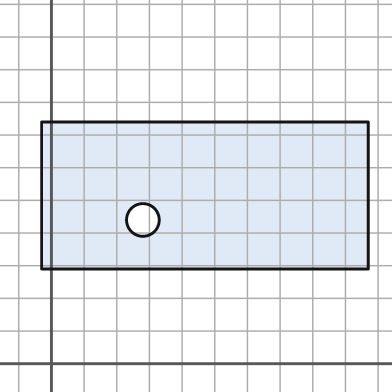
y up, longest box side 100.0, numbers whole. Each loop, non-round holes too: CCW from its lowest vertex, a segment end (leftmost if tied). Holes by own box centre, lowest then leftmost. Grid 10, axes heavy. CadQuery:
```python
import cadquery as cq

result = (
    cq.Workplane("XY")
    .moveTo(-3.0, 29.0)
    .lineTo(97.0, 29.0)
    .lineTo(97.0, 74.0)
    .lineTo(-3.0, 74.0)
    .close()
    .moveTo(28.0, 44.0)
    .circle(5.0)
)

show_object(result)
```